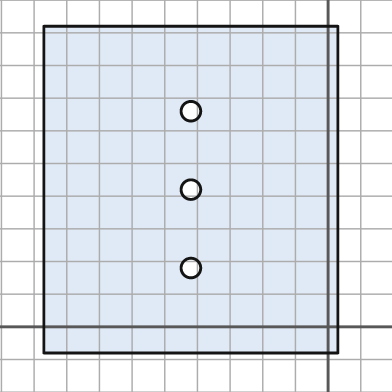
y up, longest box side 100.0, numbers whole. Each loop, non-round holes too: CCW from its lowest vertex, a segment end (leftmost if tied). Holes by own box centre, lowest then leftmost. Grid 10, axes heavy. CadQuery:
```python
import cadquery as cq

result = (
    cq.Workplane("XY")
    .moveTo(-87.0, -8.0)
    .lineTo(3.0, -8.0)
    .lineTo(3.0, 92.0)
    .lineTo(-87.0, 92.0)
    .close()
    .moveTo(-42.0, 18.0)
    .circle(3.0)
    .moveTo(-42.0, 42.0)
    .circle(3.0)
    .moveTo(-42.0, 66.0)
    .circle(3.0)
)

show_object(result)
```